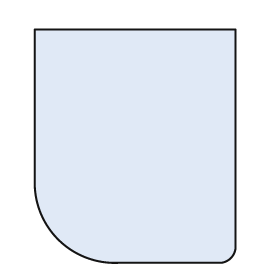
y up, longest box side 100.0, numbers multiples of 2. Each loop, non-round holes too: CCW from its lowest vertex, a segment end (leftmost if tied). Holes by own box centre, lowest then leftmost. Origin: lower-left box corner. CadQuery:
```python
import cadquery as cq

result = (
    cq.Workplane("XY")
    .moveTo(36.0, 0.0)
    .lineTo(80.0, 0.0)
    .threePointArc((84.0, 2.0), (86.0, 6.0))
    .lineTo(86.0, 100.0)
    .lineTo(0.0, 100.0)
    .lineTo(0.0, 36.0)
    .threePointArc((10.0, 10.0), (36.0, 0.0))
    .close()
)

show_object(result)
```